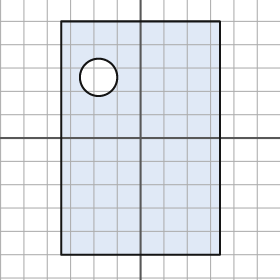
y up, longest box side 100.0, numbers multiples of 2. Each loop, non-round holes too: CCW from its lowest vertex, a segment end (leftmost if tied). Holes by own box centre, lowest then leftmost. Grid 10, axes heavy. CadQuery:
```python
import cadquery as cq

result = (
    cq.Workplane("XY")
    .moveTo(-34.0, -50.0)
    .lineTo(34.0, -50.0)
    .lineTo(34.0, 50.0)
    .lineTo(-34.0, 50.0)
    .close()
    .moveTo(-18.0, 26.0)
    .circle(8.0)
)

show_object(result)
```